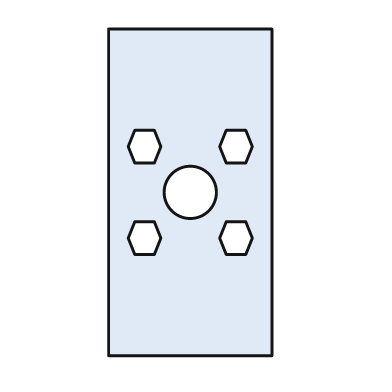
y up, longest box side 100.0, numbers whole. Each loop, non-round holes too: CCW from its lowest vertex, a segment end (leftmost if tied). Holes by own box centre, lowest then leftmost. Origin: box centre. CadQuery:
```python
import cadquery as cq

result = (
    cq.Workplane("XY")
    .moveTo(-25.0, -50.0)
    .lineTo(25.0, -50.0)
    .lineTo(25.0, 50.0)
    .lineTo(-25.0, 50.0)
    .close()
    .moveTo(-17.0, -19.0)
    .lineTo(-11.0, -19.0)
    .lineTo(-9.0, -14.0)
    .lineTo(-11.0, -9.0)
    .lineTo(-17.0, -9.0)
    .lineTo(-19.0, -14.0)
    .close()
    .moveTo(11.0, -19.0)
    .lineTo(17.0, -19.0)
    .lineTo(19.0, -14.0)
    .lineTo(17.0, -9.0)
    .lineTo(11.0, -9.0)
    .lineTo(9.0, -14.0)
    .close()
    .moveTo(0.0, 0.0)
    .circle(8.0)
    .moveTo(-17.0, 9.0)
    .lineTo(-11.0, 9.0)
    .lineTo(-9.0, 14.0)
    .lineTo(-11.0, 19.0)
    .lineTo(-17.0, 19.0)
    .lineTo(-19.0, 14.0)
    .close()
    .moveTo(11.0, 9.0)
    .lineTo(17.0, 9.0)
    .lineTo(19.0, 14.0)
    .lineTo(17.0, 19.0)
    .lineTo(11.0, 19.0)
    .lineTo(9.0, 14.0)
    .close()
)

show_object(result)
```